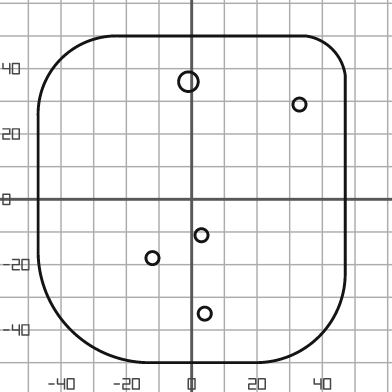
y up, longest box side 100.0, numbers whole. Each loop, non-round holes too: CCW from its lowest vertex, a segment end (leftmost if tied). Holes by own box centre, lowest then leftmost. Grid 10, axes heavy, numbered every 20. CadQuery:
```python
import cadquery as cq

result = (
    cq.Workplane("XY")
    .moveTo(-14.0, -50.0)
    .lineTo(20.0, -50.0)
    .threePointArc((39.0, -42.0), (47.0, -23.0))
    .lineTo(47.0, 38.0)
    .threePointArc((43.0, 46.0), (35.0, 50.0))
    .lineTo(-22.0, 50.0)
    .threePointArc((-40.0, 43.0), (-47.0, 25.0))
    .lineTo(-47.0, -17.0)
    .threePointArc((-37.0, -40.0), (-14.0, -50.0))
    .close()
    .moveTo(4.0, -35.0)
    .circle(2.0)
    .moveTo(-12.0, -18.0)
    .circle(2.0)
    .moveTo(3.0, -11.0)
    .circle(2.0)
    .moveTo(33.0, 29.0)
    .circle(2.0)
    .moveTo(-1.0, 36.0)
    .circle(3.0)
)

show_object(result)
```